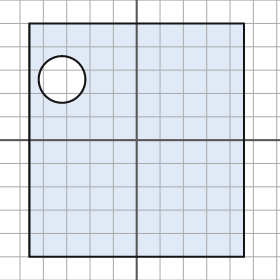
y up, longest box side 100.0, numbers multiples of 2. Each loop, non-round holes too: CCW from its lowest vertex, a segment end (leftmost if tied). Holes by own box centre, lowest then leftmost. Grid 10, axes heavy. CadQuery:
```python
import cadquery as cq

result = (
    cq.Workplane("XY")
    .moveTo(-46.0, -50.0)
    .lineTo(46.0, -50.0)
    .lineTo(46.0, 50.0)
    .lineTo(-46.0, 50.0)
    .close()
    .moveTo(-32.0, 26.0)
    .circle(10.0)
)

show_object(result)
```